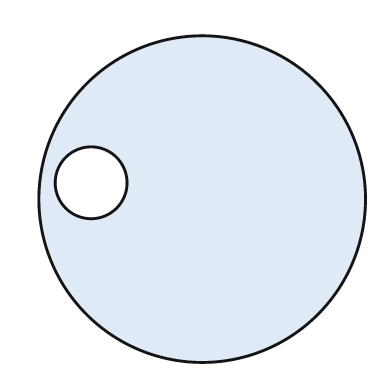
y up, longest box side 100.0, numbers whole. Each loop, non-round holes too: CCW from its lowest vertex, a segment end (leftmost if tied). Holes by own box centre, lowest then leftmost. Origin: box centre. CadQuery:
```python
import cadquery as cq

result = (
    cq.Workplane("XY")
    .moveTo(0.0, 0.0)
    .circle(50.0)
    .moveTo(-34.0, 5.0)
    .circle(11.0)
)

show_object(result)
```